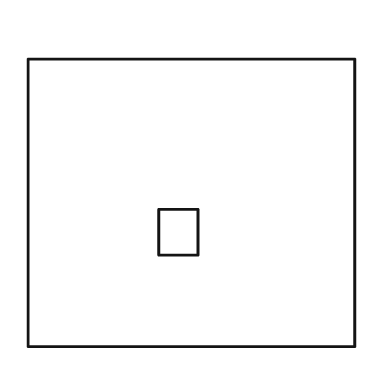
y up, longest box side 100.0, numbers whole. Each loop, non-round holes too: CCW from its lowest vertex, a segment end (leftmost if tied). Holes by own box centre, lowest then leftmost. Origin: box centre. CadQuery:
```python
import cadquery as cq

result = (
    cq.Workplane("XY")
    .moveTo(-50.0, -44.0)
    .lineTo(50.0, -44.0)
    .lineTo(50.0, 44.0)
    .lineTo(-50.0, 44.0)
    .close()
    .moveTo(-10.0, -16.0)
    .lineTo(2.0, -16.0)
    .lineTo(2.0, -2.0)
    .lineTo(-10.0, -2.0)
    .close()
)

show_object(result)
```